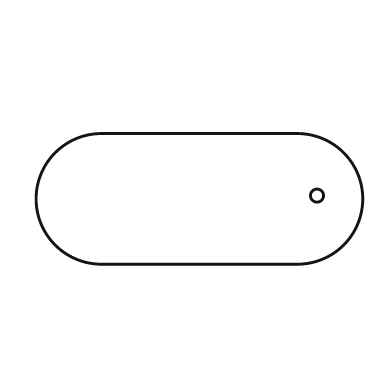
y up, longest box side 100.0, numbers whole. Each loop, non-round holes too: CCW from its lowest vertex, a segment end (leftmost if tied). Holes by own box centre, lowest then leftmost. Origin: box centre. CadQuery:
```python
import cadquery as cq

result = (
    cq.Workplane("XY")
    .moveTo(-30.0, -20.0)
    .lineTo(30.0, -20.0)
    .threePointArc((50.0, 0.0), (30.0, 20.0))
    .lineTo(-30.0, 20.0)
    .threePointArc((-50.0, 0.0), (-30.0, -20.0))
    .close()
    .moveTo(36.0, 1.0)
    .circle(2.0)
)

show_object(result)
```